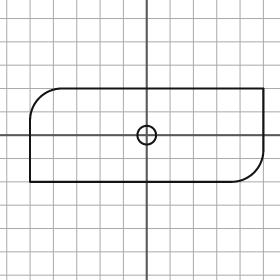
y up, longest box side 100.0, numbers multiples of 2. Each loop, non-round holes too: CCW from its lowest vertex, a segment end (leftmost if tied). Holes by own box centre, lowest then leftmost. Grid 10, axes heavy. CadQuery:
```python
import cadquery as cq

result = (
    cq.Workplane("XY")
    .moveTo(-50.0, -20.0)
    .lineTo(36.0, -20.0)
    .threePointArc((46.0, -16.0), (50.0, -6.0))
    .lineTo(50.0, 20.0)
    .lineTo(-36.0, 20.0)
    .threePointArc((-46.0, 16.0), (-50.0, 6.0))
    .close()
    .moveTo(0.0, 0.0)
    .circle(4.0)
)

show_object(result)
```